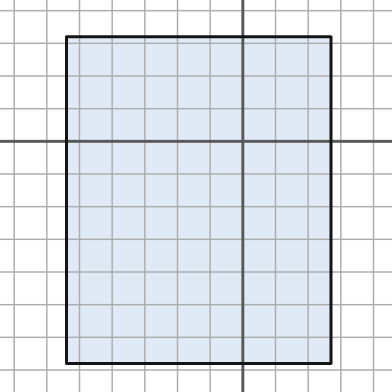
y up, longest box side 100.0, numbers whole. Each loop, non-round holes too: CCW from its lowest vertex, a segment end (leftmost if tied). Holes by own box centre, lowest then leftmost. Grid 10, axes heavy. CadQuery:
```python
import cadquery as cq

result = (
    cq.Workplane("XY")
    .moveTo(-54.0, -68.0)
    .lineTo(27.0, -68.0)
    .lineTo(27.0, 32.0)
    .lineTo(-54.0, 32.0)
    .close()
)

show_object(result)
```